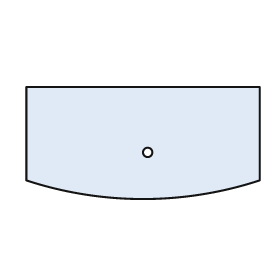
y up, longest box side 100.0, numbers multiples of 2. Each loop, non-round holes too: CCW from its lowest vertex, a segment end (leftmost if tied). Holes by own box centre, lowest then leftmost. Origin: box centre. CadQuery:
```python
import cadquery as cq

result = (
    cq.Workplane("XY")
    .moveTo(-50.0, -16.0)
    .threePointArc((0.0, -24.0), (50.0, -16.0))
    .lineTo(50.0, 24.0)
    .lineTo(-50.0, 24.0)
    .close()
    .moveTo(2.0, -4.0)
    .circle(2.0)
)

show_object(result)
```